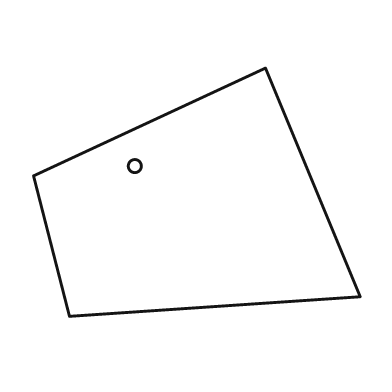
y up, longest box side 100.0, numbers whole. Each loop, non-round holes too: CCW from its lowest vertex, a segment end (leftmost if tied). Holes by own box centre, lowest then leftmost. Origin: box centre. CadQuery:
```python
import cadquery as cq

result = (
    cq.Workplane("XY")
    .moveTo(-39.0, -38.0)
    .lineTo(50.0, -32.0)
    .lineTo(21.0, 38.0)
    .lineTo(-50.0, 5.0)
    .close()
    .moveTo(-19.0, 8.0)
    .circle(2.0)
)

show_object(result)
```